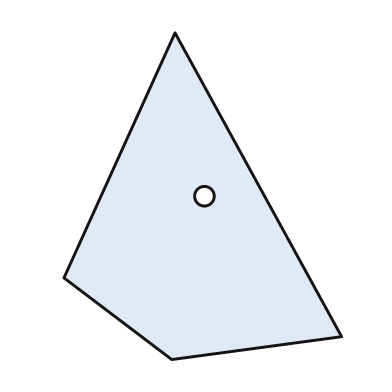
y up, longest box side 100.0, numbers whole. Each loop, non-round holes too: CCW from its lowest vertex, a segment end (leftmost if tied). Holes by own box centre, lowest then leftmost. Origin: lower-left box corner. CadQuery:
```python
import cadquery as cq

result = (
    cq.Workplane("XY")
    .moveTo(33.0, 0.0)
    .lineTo(85.0, 7.0)
    .lineTo(34.0, 100.0)
    .lineTo(0.0, 25.0)
    .close()
    .moveTo(43.0, 50.0)
    .circle(3.0)
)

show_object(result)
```